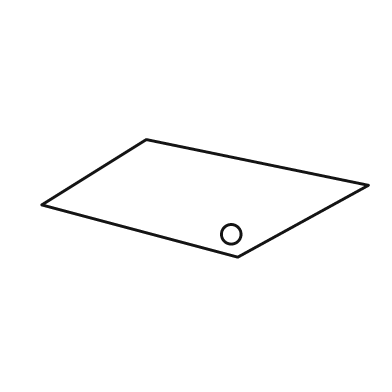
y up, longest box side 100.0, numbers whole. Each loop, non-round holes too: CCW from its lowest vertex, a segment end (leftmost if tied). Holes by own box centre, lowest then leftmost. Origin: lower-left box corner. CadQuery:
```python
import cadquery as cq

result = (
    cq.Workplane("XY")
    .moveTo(60.0, 0.0)
    .lineTo(100.0, 22.0)
    .lineTo(32.0, 36.0)
    .lineTo(0.0, 16.0)
    .close()
    .moveTo(58.0, 7.0)
    .circle(3.0)
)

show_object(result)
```